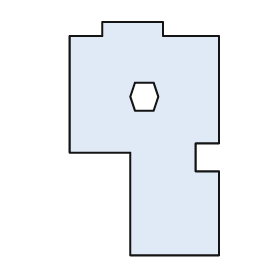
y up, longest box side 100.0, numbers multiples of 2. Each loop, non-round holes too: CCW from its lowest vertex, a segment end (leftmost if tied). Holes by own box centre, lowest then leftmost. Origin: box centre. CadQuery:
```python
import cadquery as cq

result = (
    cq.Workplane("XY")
    .moveTo(-6.0, -50.0)
    .lineTo(32.0, -50.0)
    .lineTo(32.0, -14.0)
    .lineTo(22.0, -14.0)
    .lineTo(22.0, -2.0)
    .lineTo(32.0, -2.0)
    .lineTo(32.0, 44.0)
    .lineTo(8.0, 44.0)
    .lineTo(8.0, 50.0)
    .lineTo(-18.0, 50.0)
    .lineTo(-18.0, 44.0)
    .lineTo(-32.0, 44.0)
    .lineTo(-32.0, -6.0)
    .lineTo(-6.0, -6.0)
    .close()
    .moveTo(-4.0, 12.0)
    .lineTo(4.0, 12.0)
    .lineTo(6.0, 18.0)
    .lineTo(4.0, 24.0)
    .lineTo(-4.0, 24.0)
    .lineTo(-6.0, 18.0)
    .close()
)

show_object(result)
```